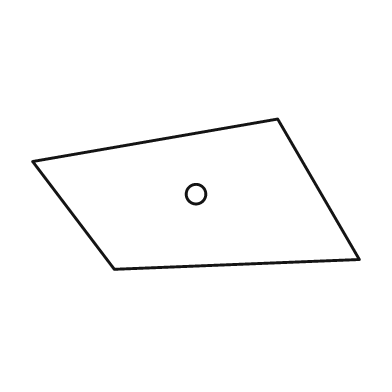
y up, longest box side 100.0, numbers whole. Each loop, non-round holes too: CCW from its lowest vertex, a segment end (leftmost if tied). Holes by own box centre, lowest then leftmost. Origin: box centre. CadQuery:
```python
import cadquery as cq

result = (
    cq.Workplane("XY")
    .moveTo(-25.0, -23.0)
    .lineTo(50.0, -20.0)
    .lineTo(25.0, 23.0)
    .lineTo(-50.0, 10.0)
    .close()
    .moveTo(0.0, 0.0)
    .circle(3.0)
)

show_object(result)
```